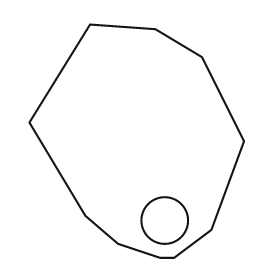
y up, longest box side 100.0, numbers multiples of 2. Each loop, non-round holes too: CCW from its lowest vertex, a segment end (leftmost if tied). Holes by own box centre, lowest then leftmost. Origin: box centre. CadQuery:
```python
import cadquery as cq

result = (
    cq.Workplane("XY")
    .moveTo(10.0, -50.0)
    .lineTo(16.0, -50.0)
    .lineTo(32.0, -38.0)
    .lineTo(46.0, 0.0)
    .lineTo(28.0, 36.0)
    .lineTo(8.0, 48.0)
    .lineTo(-20.0, 50.0)
    .lineTo(-46.0, 8.0)
    .lineTo(-22.0, -32.0)
    .lineTo(-8.0, -44.0)
    .close()
    .moveTo(12.0, -34.0)
    .circle(10.0)
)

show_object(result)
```